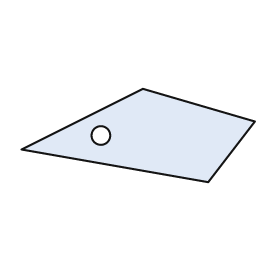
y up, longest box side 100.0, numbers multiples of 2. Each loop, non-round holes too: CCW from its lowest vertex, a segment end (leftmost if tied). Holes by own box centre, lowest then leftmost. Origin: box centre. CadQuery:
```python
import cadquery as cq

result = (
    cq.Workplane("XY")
    .moveTo(30.0, -20.0)
    .lineTo(50.0, 6.0)
    .lineTo(2.0, 20.0)
    .lineTo(-50.0, -6.0)
    .close()
    .moveTo(-16.0, 0.0)
    .circle(4.0)
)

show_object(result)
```